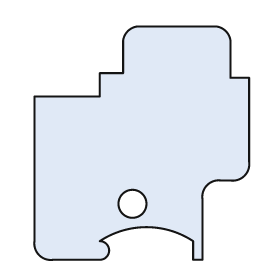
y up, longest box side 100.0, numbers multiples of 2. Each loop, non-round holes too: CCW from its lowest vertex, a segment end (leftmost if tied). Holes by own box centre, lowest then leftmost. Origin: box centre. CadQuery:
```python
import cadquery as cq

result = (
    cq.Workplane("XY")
    .moveTo(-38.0, -50.0)
    .lineTo(-18.0, -50.0)
    .threePointArc((-14.0, -46.0), (-18.0, -42.0))
    .threePointArc((2.0, -36.0), (22.0, -42.0))
    .lineTo(22.0, -50.0)
    .lineTo(26.0, -50.0)
    .lineTo(26.0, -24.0)
    .threePointArc((28.0, -18.0), (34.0, -16.0))
    .lineTo(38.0, -16.0)
    .threePointArc((44.0, -14.0), (46.0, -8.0))
    .lineTo(46.0, 28.0)
    .lineTo(38.0, 28.0)
    .lineTo(38.0, 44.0)
    .threePointArc((36.0, 48.0), (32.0, 50.0))
    .lineTo(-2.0, 50.0)
    .threePointArc((-6.0, 48.0), (-8.0, 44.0))
    .lineTo(-8.0, 30.0)
    .lineTo(-18.0, 30.0)
    .lineTo(-18.0, 20.0)
    .lineTo(-46.0, 20.0)
    .lineTo(-46.0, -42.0)
    .threePointArc((-44.0, -48.0), (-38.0, -50.0))
    .close()
    .moveTo(-4.0, -26.0)
    .circle(6.0)
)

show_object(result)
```